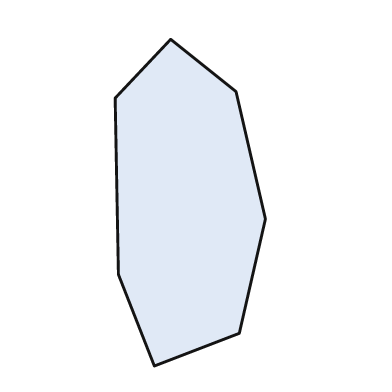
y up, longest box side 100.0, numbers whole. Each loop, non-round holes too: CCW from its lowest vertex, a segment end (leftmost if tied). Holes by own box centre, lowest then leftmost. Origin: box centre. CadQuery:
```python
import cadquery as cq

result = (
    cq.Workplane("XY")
    .moveTo(-11.0, -50.0)
    .lineTo(15.0, -40.0)
    .lineTo(23.0, -5.0)
    .lineTo(14.0, 34.0)
    .lineTo(-6.0, 50.0)
    .lineTo(-23.0, 32.0)
    .lineTo(-22.0, -22.0)
    .close()
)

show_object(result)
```